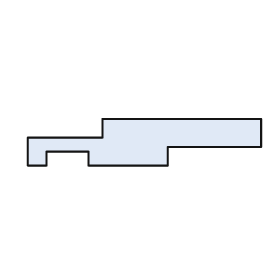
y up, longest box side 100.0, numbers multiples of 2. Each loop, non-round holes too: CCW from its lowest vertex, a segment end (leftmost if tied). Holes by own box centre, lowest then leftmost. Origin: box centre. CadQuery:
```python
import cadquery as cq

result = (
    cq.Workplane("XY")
    .moveTo(-50.0, -10.0)
    .lineTo(-42.0, -10.0)
    .lineTo(-42.0, -4.0)
    .lineTo(-24.0, -4.0)
    .lineTo(-24.0, -10.0)
    .lineTo(10.0, -10.0)
    .lineTo(10.0, -2.0)
    .lineTo(50.0, -2.0)
    .lineTo(50.0, 10.0)
    .lineTo(-18.0, 10.0)
    .lineTo(-18.0, 2.0)
    .lineTo(-50.0, 2.0)
    .close()
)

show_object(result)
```